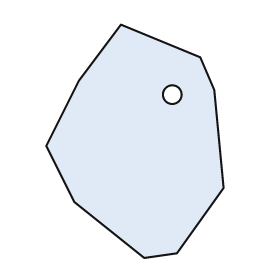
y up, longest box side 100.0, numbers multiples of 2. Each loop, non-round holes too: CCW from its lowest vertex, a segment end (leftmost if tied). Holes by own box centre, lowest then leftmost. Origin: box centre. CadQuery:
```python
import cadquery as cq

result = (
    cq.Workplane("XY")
    .moveTo(4.0, -50.0)
    .lineTo(18.0, -48.0)
    .lineTo(38.0, -20.0)
    .lineTo(34.0, 22.0)
    .lineTo(28.0, 36.0)
    .lineTo(-6.0, 50.0)
    .lineTo(-24.0, 26.0)
    .lineTo(-38.0, -2.0)
    .lineTo(-26.0, -26.0)
    .close()
    .moveTo(16.0, 20.0)
    .circle(4.0)
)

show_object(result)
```